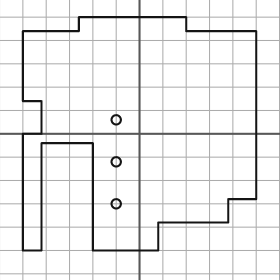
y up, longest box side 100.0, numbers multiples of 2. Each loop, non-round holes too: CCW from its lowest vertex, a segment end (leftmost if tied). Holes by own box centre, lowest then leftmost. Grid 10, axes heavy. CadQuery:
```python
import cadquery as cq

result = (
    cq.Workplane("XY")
    .moveTo(-50.0, -50.0)
    .lineTo(-42.0, -50.0)
    .lineTo(-42.0, -4.0)
    .lineTo(-20.0, -4.0)
    .lineTo(-20.0, -50.0)
    .lineTo(8.0, -50.0)
    .lineTo(8.0, -38.0)
    .lineTo(38.0, -38.0)
    .lineTo(38.0, -28.0)
    .lineTo(50.0, -28.0)
    .lineTo(50.0, 44.0)
    .lineTo(20.0, 44.0)
    .lineTo(20.0, 50.0)
    .lineTo(-26.0, 50.0)
    .lineTo(-26.0, 44.0)
    .lineTo(-50.0, 44.0)
    .lineTo(-50.0, 14.0)
    .lineTo(-42.0, 14.0)
    .lineTo(-42.0, 0.0)
    .lineTo(-50.0, 0.0)
    .close()
    .moveTo(-10.0, -30.0)
    .circle(2.0)
    .moveTo(-10.0, -12.0)
    .circle(2.0)
    .moveTo(-10.0, 6.0)
    .circle(2.0)
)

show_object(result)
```